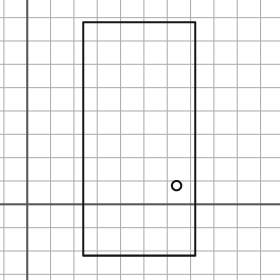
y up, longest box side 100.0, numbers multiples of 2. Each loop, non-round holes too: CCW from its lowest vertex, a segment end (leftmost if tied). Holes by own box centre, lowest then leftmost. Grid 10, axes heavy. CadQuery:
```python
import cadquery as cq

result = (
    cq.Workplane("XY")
    .moveTo(24.0, -22.0)
    .lineTo(72.0, -22.0)
    .lineTo(72.0, 78.0)
    .lineTo(24.0, 78.0)
    .close()
    .moveTo(64.0, 8.0)
    .circle(2.0)
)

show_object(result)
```